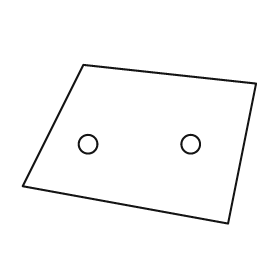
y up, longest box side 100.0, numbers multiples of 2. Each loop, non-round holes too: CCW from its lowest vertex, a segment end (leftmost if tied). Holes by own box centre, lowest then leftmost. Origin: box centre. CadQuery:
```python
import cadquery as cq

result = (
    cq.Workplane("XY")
    .moveTo(38.0, -34.0)
    .lineTo(50.0, 26.0)
    .lineTo(-24.0, 34.0)
    .lineTo(-50.0, -18.0)
    .close()
    .moveTo(-22.0, 0.0)
    .circle(4.0)
    .moveTo(22.0, 0.0)
    .circle(4.0)
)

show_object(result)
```